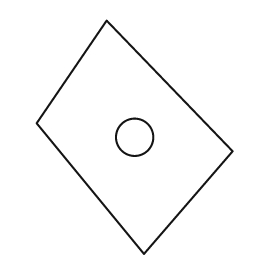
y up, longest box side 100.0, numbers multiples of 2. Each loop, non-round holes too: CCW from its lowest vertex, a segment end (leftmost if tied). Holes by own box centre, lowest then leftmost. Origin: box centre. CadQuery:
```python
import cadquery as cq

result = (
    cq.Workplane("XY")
    .moveTo(4.0, -50.0)
    .lineTo(42.0, -6.0)
    .lineTo(-12.0, 50.0)
    .lineTo(-42.0, 6.0)
    .close()
    .moveTo(0.0, 0.0)
    .circle(8.0)
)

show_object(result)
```